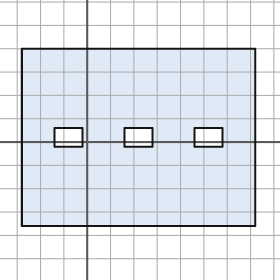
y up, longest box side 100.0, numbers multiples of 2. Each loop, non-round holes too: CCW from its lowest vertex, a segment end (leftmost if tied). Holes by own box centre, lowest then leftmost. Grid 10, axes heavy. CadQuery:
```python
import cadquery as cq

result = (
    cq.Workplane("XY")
    .moveTo(-28.0, -36.0)
    .lineTo(72.0, -36.0)
    .lineTo(72.0, 40.0)
    .lineTo(-28.0, 40.0)
    .close()
    .moveTo(-14.0, -2.0)
    .lineTo(-2.0, -2.0)
    .lineTo(-2.0, 6.0)
    .lineTo(-14.0, 6.0)
    .close()
    .moveTo(16.0, -2.0)
    .lineTo(28.0, -2.0)
    .lineTo(28.0, 6.0)
    .lineTo(16.0, 6.0)
    .close()
    .moveTo(46.0, -2.0)
    .lineTo(58.0, -2.0)
    .lineTo(58.0, 6.0)
    .lineTo(46.0, 6.0)
    .close()
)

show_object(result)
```